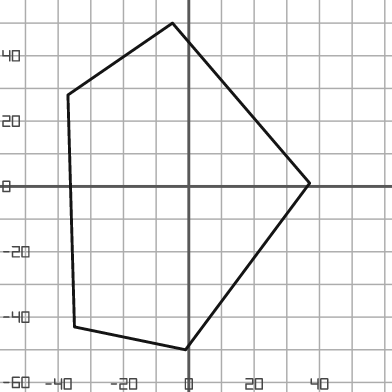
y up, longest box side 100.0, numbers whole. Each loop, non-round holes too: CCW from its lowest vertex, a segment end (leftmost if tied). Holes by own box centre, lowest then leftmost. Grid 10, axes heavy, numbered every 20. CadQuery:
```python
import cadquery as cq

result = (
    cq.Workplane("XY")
    .moveTo(-1.0, -50.0)
    .lineTo(37.0, 1.0)
    .lineTo(-5.0, 50.0)
    .lineTo(-37.0, 28.0)
    .lineTo(-35.0, -43.0)
    .close()
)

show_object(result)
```